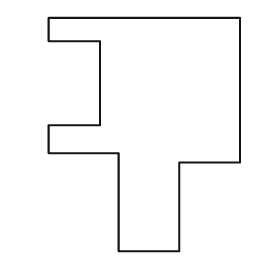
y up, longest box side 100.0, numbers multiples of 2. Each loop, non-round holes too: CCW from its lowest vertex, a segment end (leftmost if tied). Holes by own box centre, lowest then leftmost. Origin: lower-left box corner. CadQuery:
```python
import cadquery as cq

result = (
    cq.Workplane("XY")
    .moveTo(30.0, 0.0)
    .lineTo(56.0, 0.0)
    .lineTo(56.0, 38.0)
    .lineTo(82.0, 38.0)
    .lineTo(82.0, 100.0)
    .lineTo(0.0, 100.0)
    .lineTo(0.0, 90.0)
    .lineTo(22.0, 90.0)
    .lineTo(22.0, 54.0)
    .lineTo(0.0, 54.0)
    .lineTo(0.0, 42.0)
    .lineTo(30.0, 42.0)
    .close()
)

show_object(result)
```